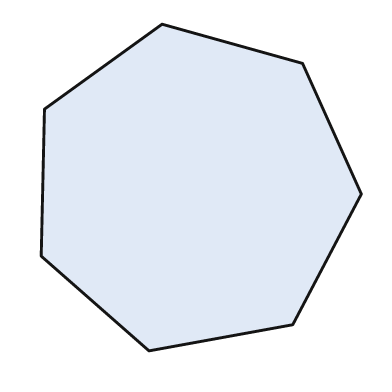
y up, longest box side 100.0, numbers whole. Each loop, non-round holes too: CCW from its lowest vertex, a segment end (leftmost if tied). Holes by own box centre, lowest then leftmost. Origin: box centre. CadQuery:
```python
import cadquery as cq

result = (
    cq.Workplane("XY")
    .moveTo(-16.0, -50.0)
    .lineTo(28.0, -42.0)
    .lineTo(49.0, -2.0)
    .lineTo(31.0, 38.0)
    .lineTo(-12.0, 50.0)
    .lineTo(-48.0, 24.0)
    .lineTo(-49.0, -21.0)
    .close()
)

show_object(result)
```